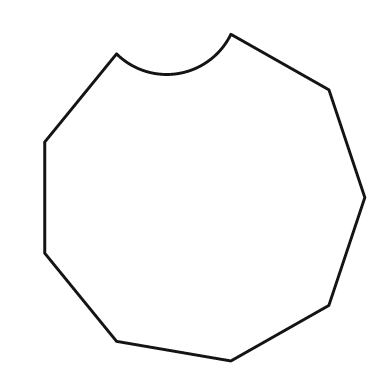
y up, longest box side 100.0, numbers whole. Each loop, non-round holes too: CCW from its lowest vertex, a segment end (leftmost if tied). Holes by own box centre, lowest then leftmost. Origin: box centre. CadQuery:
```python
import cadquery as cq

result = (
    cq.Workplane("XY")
    .moveTo(8.0, -50.0)
    .lineTo(38.0, -33.0)
    .lineTo(49.0, 0.0)
    .lineTo(38.0, 33.0)
    .lineTo(8.0, 50.0)
    .threePointArc((-8.0, 38.0), (-27.0, 44.0))
    .lineTo(-49.0, 17.0)
    .lineTo(-49.0, -17.0)
    .lineTo(-27.0, -44.0)
    .close()
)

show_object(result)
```